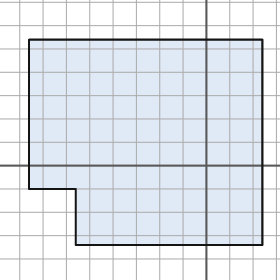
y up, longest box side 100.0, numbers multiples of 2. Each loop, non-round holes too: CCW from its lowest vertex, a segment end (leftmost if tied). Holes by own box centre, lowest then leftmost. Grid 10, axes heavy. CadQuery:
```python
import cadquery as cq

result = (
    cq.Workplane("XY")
    .moveTo(-56.0, -34.0)
    .lineTo(24.0, -34.0)
    .lineTo(24.0, 54.0)
    .lineTo(-76.0, 54.0)
    .lineTo(-76.0, -10.0)
    .lineTo(-56.0, -10.0)
    .close()
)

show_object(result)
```